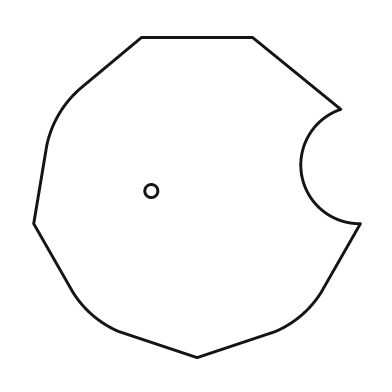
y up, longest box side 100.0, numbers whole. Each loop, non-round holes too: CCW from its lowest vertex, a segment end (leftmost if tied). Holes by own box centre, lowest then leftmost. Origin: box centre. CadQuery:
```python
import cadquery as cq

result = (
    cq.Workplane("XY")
    .moveTo(0.0, -49.0)
    .lineTo(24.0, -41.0)
    .threePointArc((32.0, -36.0), (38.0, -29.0))
    .lineTo(50.0, -8.0)
    .threePointArc((32.0, 7.0), (44.0, 27.0))
    .lineTo(17.0, 49.0)
    .lineTo(-17.0, 49.0)
    .lineTo(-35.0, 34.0)
    .threePointArc((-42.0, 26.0), (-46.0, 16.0))
    .lineTo(-50.0, -8.0)
    .lineTo(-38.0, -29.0)
    .threePointArc((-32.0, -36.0), (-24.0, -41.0))
    .close()
    .moveTo(-14.0, 2.0)
    .circle(2.0)
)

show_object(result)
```